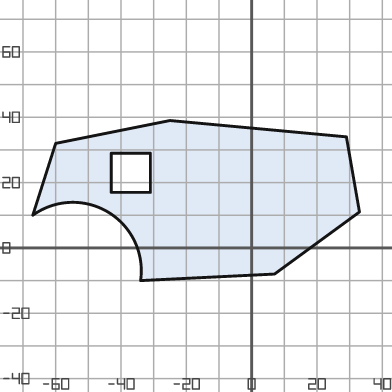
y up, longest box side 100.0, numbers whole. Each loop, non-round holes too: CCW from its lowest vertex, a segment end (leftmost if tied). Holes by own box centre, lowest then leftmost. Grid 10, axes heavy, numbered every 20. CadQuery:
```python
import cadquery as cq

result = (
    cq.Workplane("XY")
    .moveTo(-34.0, -10.0)
    .lineTo(7.0, -8.0)
    .lineTo(33.0, 11.0)
    .lineTo(29.0, 34.0)
    .lineTo(-25.0, 39.0)
    .lineTo(-60.0, 32.0)
    .lineTo(-67.0, 10.0)
    .threePointArc((-44.0, 11.0), (-34.0, -10.0))
    .close()
    .moveTo(-43.0, 17.0)
    .lineTo(-31.0, 17.0)
    .lineTo(-31.0, 29.0)
    .lineTo(-43.0, 29.0)
    .close()
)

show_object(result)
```